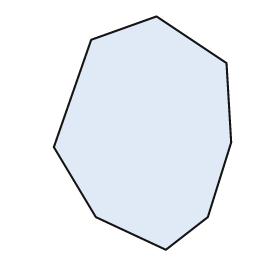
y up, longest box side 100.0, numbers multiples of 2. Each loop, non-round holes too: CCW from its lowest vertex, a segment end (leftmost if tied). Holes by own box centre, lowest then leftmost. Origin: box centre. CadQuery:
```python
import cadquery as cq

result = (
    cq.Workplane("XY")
    .moveTo(10.0, -50.0)
    .lineTo(28.0, -36.0)
    .lineTo(38.0, -4.0)
    .lineTo(36.0, 30.0)
    .lineTo(6.0, 50.0)
    .lineTo(-22.0, 40.0)
    .lineTo(-38.0, -6.0)
    .lineTo(-20.0, -36.0)
    .close()
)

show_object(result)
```